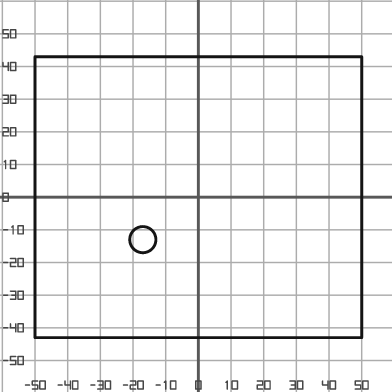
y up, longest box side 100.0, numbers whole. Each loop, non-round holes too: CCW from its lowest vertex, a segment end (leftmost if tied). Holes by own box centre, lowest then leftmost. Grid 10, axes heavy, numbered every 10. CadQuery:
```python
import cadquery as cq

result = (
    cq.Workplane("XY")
    .moveTo(-50.0, -43.0)
    .lineTo(50.0, -43.0)
    .lineTo(50.0, 43.0)
    .lineTo(-50.0, 43.0)
    .close()
    .moveTo(-17.0, -13.0)
    .circle(4.0)
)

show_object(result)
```